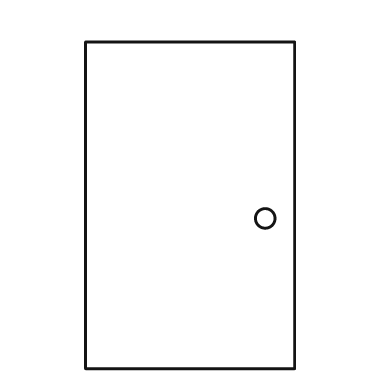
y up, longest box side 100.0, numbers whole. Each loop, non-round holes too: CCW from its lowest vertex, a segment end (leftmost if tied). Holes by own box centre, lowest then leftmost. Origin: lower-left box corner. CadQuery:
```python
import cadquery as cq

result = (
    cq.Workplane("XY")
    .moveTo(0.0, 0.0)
    .lineTo(64.0, 0.0)
    .lineTo(64.0, 100.0)
    .lineTo(0.0, 100.0)
    .close()
    .moveTo(55.0, 46.0)
    .circle(3.0)
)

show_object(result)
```